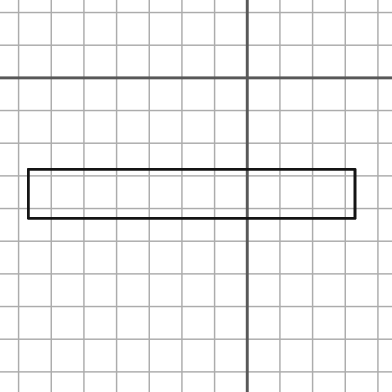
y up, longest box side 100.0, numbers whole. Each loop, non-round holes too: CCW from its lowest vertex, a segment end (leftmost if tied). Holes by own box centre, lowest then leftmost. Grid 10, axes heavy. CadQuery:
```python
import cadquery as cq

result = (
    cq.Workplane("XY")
    .moveTo(-67.0, -43.0)
    .lineTo(33.0, -43.0)
    .lineTo(33.0, -28.0)
    .lineTo(-67.0, -28.0)
    .close()
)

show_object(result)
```